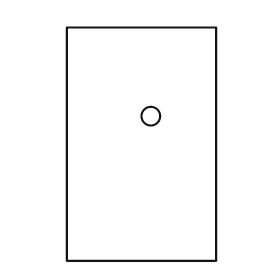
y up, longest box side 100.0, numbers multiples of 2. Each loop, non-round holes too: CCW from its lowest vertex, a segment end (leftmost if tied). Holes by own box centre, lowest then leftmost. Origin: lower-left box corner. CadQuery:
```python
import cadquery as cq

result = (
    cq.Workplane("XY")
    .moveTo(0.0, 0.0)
    .lineTo(64.0, 0.0)
    .lineTo(64.0, 100.0)
    .lineTo(0.0, 100.0)
    .close()
    .moveTo(36.0, 62.0)
    .circle(4.0)
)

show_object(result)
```